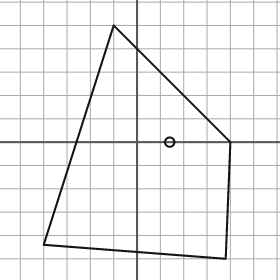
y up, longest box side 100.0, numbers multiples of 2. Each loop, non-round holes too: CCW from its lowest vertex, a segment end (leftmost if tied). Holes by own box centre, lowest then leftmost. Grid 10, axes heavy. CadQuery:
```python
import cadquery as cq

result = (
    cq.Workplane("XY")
    .moveTo(38.0, -50.0)
    .lineTo(40.0, 0.0)
    .lineTo(-10.0, 50.0)
    .lineTo(-40.0, -44.0)
    .close()
    .moveTo(14.0, 0.0)
    .circle(2.0)
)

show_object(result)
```